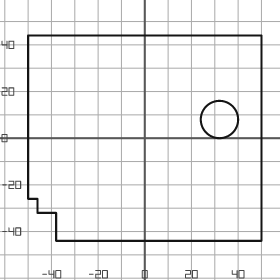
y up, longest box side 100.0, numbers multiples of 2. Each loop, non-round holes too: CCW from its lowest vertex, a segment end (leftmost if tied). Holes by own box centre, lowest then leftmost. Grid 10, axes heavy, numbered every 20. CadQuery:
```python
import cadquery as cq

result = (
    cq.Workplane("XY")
    .moveTo(-38.0, -44.0)
    .lineTo(50.0, -44.0)
    .lineTo(50.0, 44.0)
    .lineTo(-50.0, 44.0)
    .lineTo(-50.0, -26.0)
    .lineTo(-46.0, -26.0)
    .lineTo(-46.0, -32.0)
    .lineTo(-38.0, -32.0)
    .close()
    .moveTo(32.0, 8.0)
    .circle(8.0)
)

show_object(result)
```